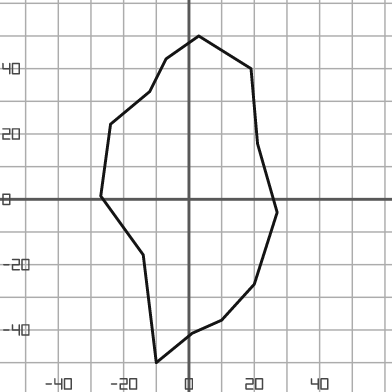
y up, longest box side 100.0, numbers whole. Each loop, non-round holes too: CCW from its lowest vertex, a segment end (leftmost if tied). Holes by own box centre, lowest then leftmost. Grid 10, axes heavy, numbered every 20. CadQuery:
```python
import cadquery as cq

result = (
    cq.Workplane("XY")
    .moveTo(-10.0, -50.0)
    .lineTo(1.0, -41.0)
    .lineTo(10.0, -37.0)
    .lineTo(20.0, -26.0)
    .lineTo(27.0, -4.0)
    .lineTo(21.0, 17.0)
    .lineTo(19.0, 40.0)
    .lineTo(3.0, 50.0)
    .lineTo(-7.0, 43.0)
    .lineTo(-12.0, 33.0)
    .lineTo(-24.0, 23.0)
    .lineTo(-27.0, 1.0)
    .lineTo(-14.0, -17.0)
    .close()
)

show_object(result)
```